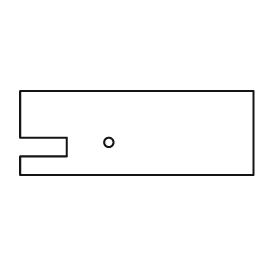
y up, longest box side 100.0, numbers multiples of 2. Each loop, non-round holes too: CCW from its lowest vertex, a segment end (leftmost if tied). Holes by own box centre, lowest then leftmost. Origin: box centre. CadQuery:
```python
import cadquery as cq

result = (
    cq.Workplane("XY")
    .moveTo(-50.0, -18.0)
    .lineTo(50.0, -18.0)
    .lineTo(50.0, 18.0)
    .lineTo(-50.0, 18.0)
    .lineTo(-50.0, -2.0)
    .lineTo(-30.0, -2.0)
    .lineTo(-30.0, -10.0)
    .lineTo(-50.0, -10.0)
    .close()
    .moveTo(-12.0, -4.0)
    .circle(2.0)
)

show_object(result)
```